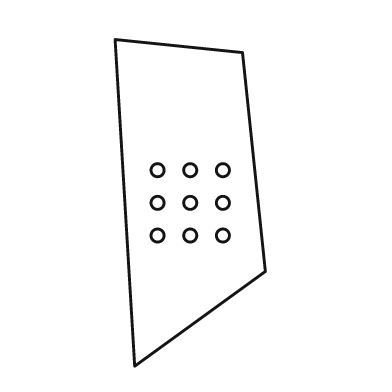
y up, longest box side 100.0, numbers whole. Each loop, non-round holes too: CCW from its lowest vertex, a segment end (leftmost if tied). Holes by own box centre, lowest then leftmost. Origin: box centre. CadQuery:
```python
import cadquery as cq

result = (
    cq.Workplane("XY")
    .moveTo(-17.0, -50.0)
    .lineTo(23.0, -21.0)
    .lineTo(16.0, 46.0)
    .lineTo(-23.0, 50.0)
    .close()
    .moveTo(-10.0, -10.0)
    .circle(2.0)
    .moveTo(0.0, -10.0)
    .circle(2.0)
    .moveTo(10.0, -10.0)
    .circle(2.0)
    .moveTo(-10.0, 0.0)
    .circle(2.0)
    .moveTo(0.0, 0.0)
    .circle(2.0)
    .moveTo(10.0, 0.0)
    .circle(2.0)
    .moveTo(-10.0, 10.0)
    .circle(2.0)
    .moveTo(0.0, 10.0)
    .circle(2.0)
    .moveTo(10.0, 10.0)
    .circle(2.0)
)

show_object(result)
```